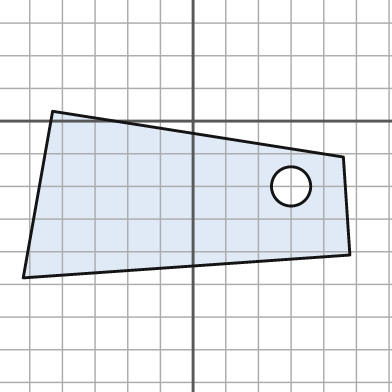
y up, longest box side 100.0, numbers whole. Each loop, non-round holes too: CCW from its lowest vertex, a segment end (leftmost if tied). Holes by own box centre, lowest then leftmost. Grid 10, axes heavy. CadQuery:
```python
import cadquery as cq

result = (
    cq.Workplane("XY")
    .moveTo(-52.0, -48.0)
    .lineTo(48.0, -41.0)
    .lineTo(46.0, -11.0)
    .lineTo(-43.0, 3.0)
    .close()
    .moveTo(30.0, -20.0)
    .circle(6.0)
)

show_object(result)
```